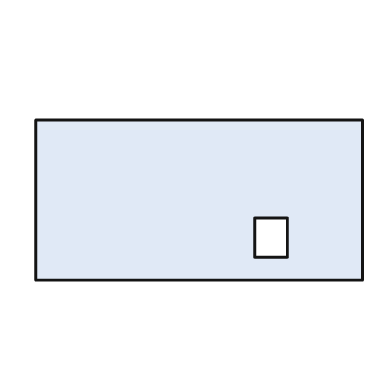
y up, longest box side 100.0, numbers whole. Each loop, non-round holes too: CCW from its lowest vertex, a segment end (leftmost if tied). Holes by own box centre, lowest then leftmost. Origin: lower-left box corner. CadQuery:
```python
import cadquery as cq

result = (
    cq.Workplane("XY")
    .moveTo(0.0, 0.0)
    .lineTo(100.0, 0.0)
    .lineTo(100.0, 49.0)
    .lineTo(0.0, 49.0)
    .close()
    .moveTo(67.0, 7.0)
    .lineTo(77.0, 7.0)
    .lineTo(77.0, 19.0)
    .lineTo(67.0, 19.0)
    .close()
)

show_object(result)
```